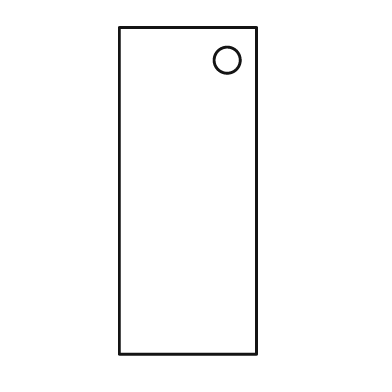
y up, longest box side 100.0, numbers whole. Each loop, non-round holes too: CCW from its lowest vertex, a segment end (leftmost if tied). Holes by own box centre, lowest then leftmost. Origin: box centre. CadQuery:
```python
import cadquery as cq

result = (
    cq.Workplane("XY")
    .moveTo(-21.0, -50.0)
    .lineTo(21.0, -50.0)
    .lineTo(21.0, 50.0)
    .lineTo(-21.0, 50.0)
    .close()
    .moveTo(12.0, 40.0)
    .circle(4.0)
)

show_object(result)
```